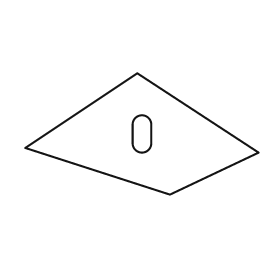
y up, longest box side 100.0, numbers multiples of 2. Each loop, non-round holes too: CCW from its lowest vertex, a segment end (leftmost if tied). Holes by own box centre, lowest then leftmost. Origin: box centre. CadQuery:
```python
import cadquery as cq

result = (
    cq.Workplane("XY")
    .moveTo(12.0, -26.0)
    .lineTo(50.0, -8.0)
    .lineTo(-2.0, 26.0)
    .lineTo(-50.0, -6.0)
    .close()
    .moveTo(-4.0, -4.0)
    .threePointArc((0.0, -8.0), (4.0, -4.0))
    .lineTo(4.0, 4.0)
    .threePointArc((0.0, 8.0), (-4.0, 4.0))
    .close()
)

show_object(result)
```